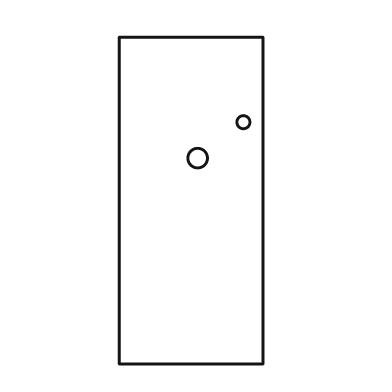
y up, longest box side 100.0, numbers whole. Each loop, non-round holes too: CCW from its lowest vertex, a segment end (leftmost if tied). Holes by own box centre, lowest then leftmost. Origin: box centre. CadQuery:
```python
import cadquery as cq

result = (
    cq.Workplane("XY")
    .moveTo(-22.0, -50.0)
    .lineTo(22.0, -50.0)
    .lineTo(22.0, 50.0)
    .lineTo(-22.0, 50.0)
    .close()
    .moveTo(2.0, 13.0)
    .circle(3.0)
    .moveTo(16.0, 24.0)
    .circle(2.0)
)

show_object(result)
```